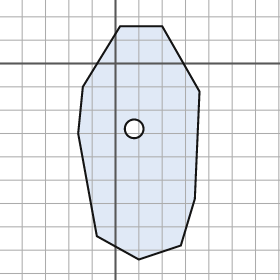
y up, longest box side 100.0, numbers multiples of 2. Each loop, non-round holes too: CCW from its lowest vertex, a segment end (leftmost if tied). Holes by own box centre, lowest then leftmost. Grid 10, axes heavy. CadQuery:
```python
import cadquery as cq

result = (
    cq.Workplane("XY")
    .moveTo(10.0, -84.0)
    .lineTo(28.0, -78.0)
    .lineTo(34.0, -58.0)
    .lineTo(36.0, -12.0)
    .lineTo(20.0, 16.0)
    .lineTo(2.0, 16.0)
    .lineTo(-14.0, -10.0)
    .lineTo(-16.0, -30.0)
    .lineTo(-8.0, -74.0)
    .close()
    .moveTo(8.0, -28.0)
    .circle(4.0)
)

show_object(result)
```